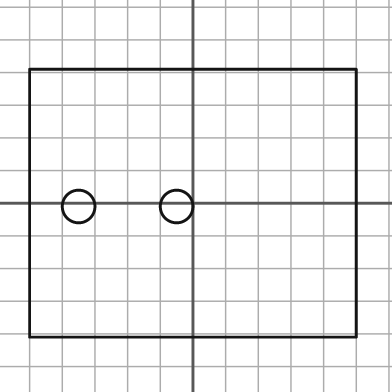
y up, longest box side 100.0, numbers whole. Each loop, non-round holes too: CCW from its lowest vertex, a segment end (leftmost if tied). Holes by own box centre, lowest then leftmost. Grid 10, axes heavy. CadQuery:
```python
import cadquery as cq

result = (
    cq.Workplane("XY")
    .moveTo(-50.0, -41.0)
    .lineTo(50.0, -41.0)
    .lineTo(50.0, 41.0)
    .lineTo(-50.0, 41.0)
    .close()
    .moveTo(-35.0, -1.0)
    .circle(5.0)
    .moveTo(-5.0, -1.0)
    .circle(5.0)
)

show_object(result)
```